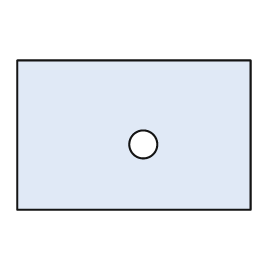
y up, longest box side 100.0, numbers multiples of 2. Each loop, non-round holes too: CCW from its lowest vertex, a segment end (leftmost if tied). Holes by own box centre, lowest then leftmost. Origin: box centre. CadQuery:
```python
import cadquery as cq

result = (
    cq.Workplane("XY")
    .moveTo(-50.0, -32.0)
    .lineTo(50.0, -32.0)
    .lineTo(50.0, 32.0)
    .lineTo(-50.0, 32.0)
    .close()
    .moveTo(4.0, -4.0)
    .circle(6.0)
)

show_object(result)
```